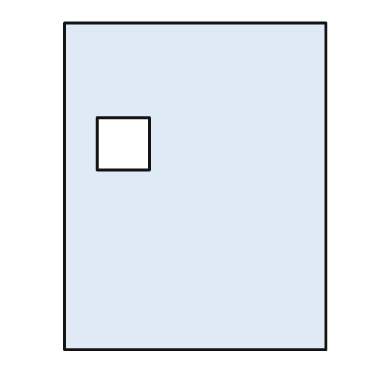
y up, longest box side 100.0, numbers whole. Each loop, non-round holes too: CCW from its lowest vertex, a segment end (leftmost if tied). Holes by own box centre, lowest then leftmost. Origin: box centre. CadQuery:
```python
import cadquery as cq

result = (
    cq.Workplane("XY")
    .moveTo(-40.0, -50.0)
    .lineTo(40.0, -50.0)
    .lineTo(40.0, 50.0)
    .lineTo(-40.0, 50.0)
    .close()
    .moveTo(-30.0, 5.0)
    .lineTo(-14.0, 5.0)
    .lineTo(-14.0, 21.0)
    .lineTo(-30.0, 21.0)
    .close()
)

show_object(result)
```